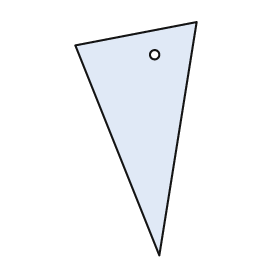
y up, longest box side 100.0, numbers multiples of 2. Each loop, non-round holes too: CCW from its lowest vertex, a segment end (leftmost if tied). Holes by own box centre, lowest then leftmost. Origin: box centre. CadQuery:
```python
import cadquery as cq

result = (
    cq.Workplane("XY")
    .moveTo(10.0, -50.0)
    .lineTo(26.0, 50.0)
    .lineTo(-26.0, 40.0)
    .close()
    .moveTo(8.0, 36.0)
    .circle(2.0)
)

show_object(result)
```